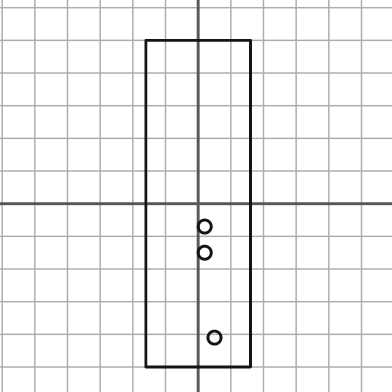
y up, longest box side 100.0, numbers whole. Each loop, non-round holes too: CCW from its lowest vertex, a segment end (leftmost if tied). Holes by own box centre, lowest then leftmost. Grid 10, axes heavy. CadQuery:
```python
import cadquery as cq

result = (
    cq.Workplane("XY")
    .moveTo(-16.0, -50.0)
    .lineTo(16.0, -50.0)
    .lineTo(16.0, 50.0)
    .lineTo(-16.0, 50.0)
    .close()
    .moveTo(5.0, -41.0)
    .circle(2.0)
    .moveTo(2.0, -15.0)
    .circle(2.0)
    .moveTo(2.0, -7.0)
    .circle(2.0)
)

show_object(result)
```